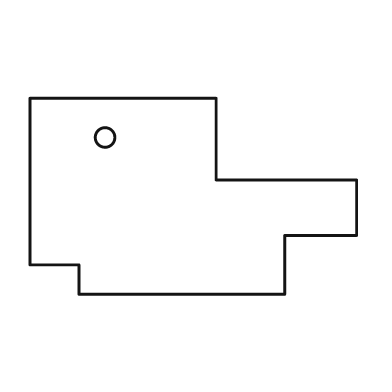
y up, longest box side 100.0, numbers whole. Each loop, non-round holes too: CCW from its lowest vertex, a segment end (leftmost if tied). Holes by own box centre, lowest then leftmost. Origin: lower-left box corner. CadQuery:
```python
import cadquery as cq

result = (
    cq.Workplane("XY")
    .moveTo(15.0, 0.0)
    .lineTo(78.0, 0.0)
    .lineTo(78.0, 18.0)
    .lineTo(100.0, 18.0)
    .lineTo(100.0, 35.0)
    .lineTo(57.0, 35.0)
    .lineTo(57.0, 60.0)
    .lineTo(0.0, 60.0)
    .lineTo(0.0, 9.0)
    .lineTo(15.0, 9.0)
    .close()
    .moveTo(23.0, 48.0)
    .circle(3.0)
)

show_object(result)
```